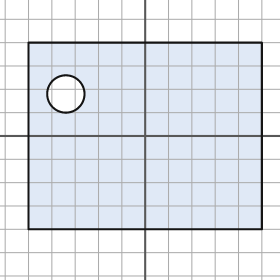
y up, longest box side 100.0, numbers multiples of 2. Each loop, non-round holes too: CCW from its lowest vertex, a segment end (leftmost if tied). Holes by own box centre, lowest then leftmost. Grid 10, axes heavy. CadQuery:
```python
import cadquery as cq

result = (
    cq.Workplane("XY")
    .moveTo(-50.0, -40.0)
    .lineTo(50.0, -40.0)
    .lineTo(50.0, 40.0)
    .lineTo(-50.0, 40.0)
    .close()
    .moveTo(-34.0, 18.0)
    .circle(8.0)
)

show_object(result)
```